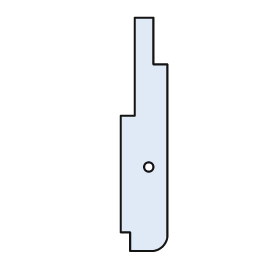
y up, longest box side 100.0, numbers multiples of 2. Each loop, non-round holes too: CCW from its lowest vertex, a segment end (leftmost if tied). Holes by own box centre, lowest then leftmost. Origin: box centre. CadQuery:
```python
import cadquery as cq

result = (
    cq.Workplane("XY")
    .moveTo(-6.0, -50.0)
    .lineTo(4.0, -50.0)
    .threePointArc((8.0, -48.0), (10.0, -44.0))
    .lineTo(10.0, 30.0)
    .lineTo(4.0, 30.0)
    .lineTo(4.0, 50.0)
    .lineTo(-4.0, 50.0)
    .lineTo(-4.0, 8.0)
    .lineTo(-10.0, 8.0)
    .lineTo(-10.0, -42.0)
    .lineTo(-6.0, -42.0)
    .close()
    .moveTo(2.0, -14.0)
    .circle(2.0)
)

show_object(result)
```